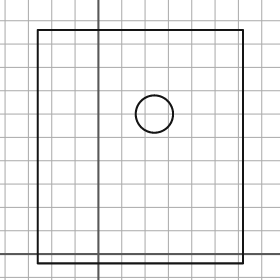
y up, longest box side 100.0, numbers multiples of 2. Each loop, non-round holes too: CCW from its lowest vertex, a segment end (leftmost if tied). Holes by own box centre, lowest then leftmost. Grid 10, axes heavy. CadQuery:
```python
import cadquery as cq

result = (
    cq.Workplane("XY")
    .moveTo(-26.0, -4.0)
    .lineTo(62.0, -4.0)
    .lineTo(62.0, 96.0)
    .lineTo(-26.0, 96.0)
    .close()
    .moveTo(24.0, 60.0)
    .circle(8.0)
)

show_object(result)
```